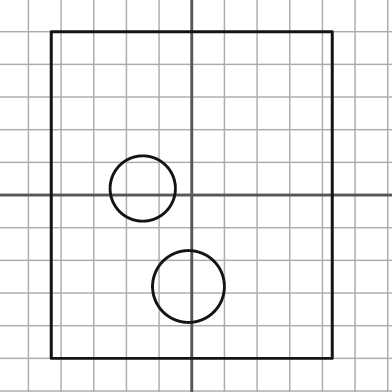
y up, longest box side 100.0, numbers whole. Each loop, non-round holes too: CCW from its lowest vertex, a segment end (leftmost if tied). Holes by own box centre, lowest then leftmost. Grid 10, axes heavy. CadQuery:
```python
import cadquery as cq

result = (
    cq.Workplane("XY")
    .moveTo(-43.0, -50.0)
    .lineTo(43.0, -50.0)
    .lineTo(43.0, 50.0)
    .lineTo(-43.0, 50.0)
    .close()
    .moveTo(-1.0, -28.0)
    .circle(11.0)
    .moveTo(-15.0, 2.0)
    .circle(10.0)
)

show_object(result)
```